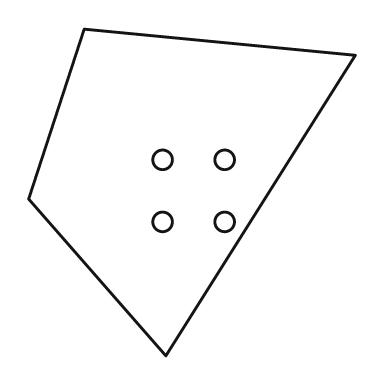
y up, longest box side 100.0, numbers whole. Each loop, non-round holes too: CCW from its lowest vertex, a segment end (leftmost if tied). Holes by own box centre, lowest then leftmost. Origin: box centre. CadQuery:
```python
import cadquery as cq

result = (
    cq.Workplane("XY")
    .moveTo(-8.0, -50.0)
    .lineTo(50.0, 42.0)
    .lineTo(-33.0, 50.0)
    .lineTo(-50.0, -2.0)
    .close()
    .moveTo(-9.0, -9.0)
    .circle(3.0)
    .moveTo(10.0, -9.0)
    .circle(3.0)
    .moveTo(-9.0, 10.0)
    .circle(3.0)
    .moveTo(10.0, 10.0)
    .circle(3.0)
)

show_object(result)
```